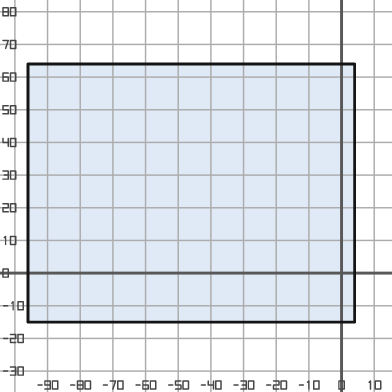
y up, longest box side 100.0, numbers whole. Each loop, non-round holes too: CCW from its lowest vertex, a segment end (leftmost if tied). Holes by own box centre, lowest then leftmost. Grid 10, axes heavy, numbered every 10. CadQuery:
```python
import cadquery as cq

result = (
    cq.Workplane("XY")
    .moveTo(-96.0, -15.0)
    .lineTo(4.0, -15.0)
    .lineTo(4.0, 64.0)
    .lineTo(-96.0, 64.0)
    .close()
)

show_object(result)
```